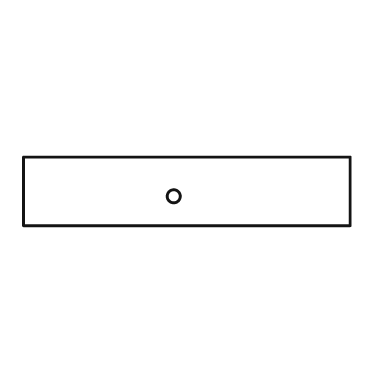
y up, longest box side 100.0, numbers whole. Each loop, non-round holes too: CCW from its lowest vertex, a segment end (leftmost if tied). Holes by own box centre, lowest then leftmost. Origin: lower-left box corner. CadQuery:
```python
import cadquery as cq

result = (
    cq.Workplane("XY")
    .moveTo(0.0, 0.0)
    .lineTo(100.0, 0.0)
    .lineTo(100.0, 21.0)
    .lineTo(0.0, 21.0)
    .close()
    .moveTo(46.0, 9.0)
    .circle(2.0)
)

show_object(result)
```